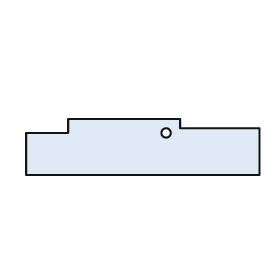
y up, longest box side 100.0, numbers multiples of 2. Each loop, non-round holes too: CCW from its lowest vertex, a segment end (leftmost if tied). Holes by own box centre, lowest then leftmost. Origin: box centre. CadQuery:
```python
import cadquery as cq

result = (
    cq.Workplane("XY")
    .moveTo(-50.0, -12.0)
    .lineTo(50.0, -12.0)
    .lineTo(50.0, 8.0)
    .lineTo(16.0, 8.0)
    .lineTo(16.0, 12.0)
    .lineTo(-32.0, 12.0)
    .lineTo(-32.0, 6.0)
    .lineTo(-50.0, 6.0)
    .close()
    .moveTo(10.0, 6.0)
    .circle(2.0)
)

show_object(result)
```